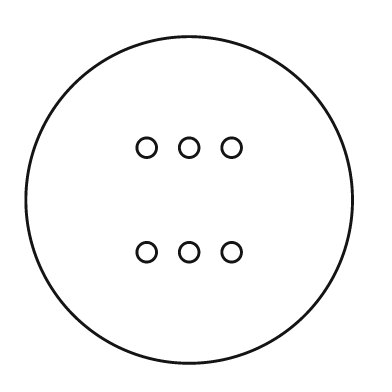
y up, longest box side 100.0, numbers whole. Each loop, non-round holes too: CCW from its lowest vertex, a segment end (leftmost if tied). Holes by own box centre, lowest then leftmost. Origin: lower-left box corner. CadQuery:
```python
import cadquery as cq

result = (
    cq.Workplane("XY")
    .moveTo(50.0, 50.0)
    .circle(50.0)
    .moveTo(37.0, 34.0)
    .circle(3.0)
    .moveTo(50.0, 34.0)
    .circle(3.0)
    .moveTo(63.0, 34.0)
    .circle(3.0)
    .moveTo(37.0, 66.0)
    .circle(3.0)
    .moveTo(50.0, 66.0)
    .circle(3.0)
    .moveTo(63.0, 66.0)
    .circle(3.0)
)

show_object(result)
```